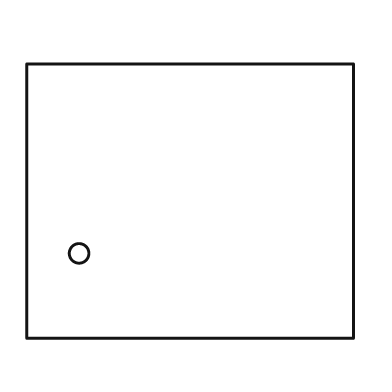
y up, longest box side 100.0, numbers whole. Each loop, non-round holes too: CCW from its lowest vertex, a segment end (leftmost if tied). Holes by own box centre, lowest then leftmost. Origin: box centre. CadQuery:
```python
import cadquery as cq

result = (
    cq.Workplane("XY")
    .moveTo(-50.0, -42.0)
    .lineTo(50.0, -42.0)
    .lineTo(50.0, 42.0)
    .lineTo(-50.0, 42.0)
    .close()
    .moveTo(-34.0, -16.0)
    .circle(3.0)
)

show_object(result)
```